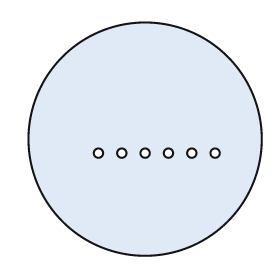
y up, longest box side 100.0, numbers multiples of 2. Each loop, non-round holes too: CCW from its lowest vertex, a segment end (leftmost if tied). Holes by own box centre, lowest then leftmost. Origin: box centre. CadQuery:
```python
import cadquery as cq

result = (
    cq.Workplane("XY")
    .moveTo(0.0, 0.0)
    .circle(50.0)
    .moveTo(-20.0, -6.0)
    .circle(2.0)
    .moveTo(-10.0, -6.0)
    .circle(2.0)
    .moveTo(0.0, -6.0)
    .circle(2.0)
    .moveTo(10.0, -6.0)
    .circle(2.0)
    .moveTo(20.0, -6.0)
    .circle(2.0)
    .moveTo(30.0, -6.0)
    .circle(2.0)
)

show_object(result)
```